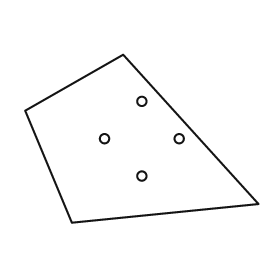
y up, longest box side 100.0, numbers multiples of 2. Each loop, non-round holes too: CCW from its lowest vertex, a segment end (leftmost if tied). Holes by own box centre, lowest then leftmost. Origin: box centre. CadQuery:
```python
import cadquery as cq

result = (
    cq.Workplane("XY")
    .moveTo(-30.0, -36.0)
    .lineTo(50.0, -28.0)
    .lineTo(-8.0, 36.0)
    .lineTo(-50.0, 12.0)
    .close()
    .moveTo(0.0, -16.0)
    .circle(2.0)
    .moveTo(-16.0, 0.0)
    .circle(2.0)
    .moveTo(16.0, 0.0)
    .circle(2.0)
    .moveTo(0.0, 16.0)
    .circle(2.0)
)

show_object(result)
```